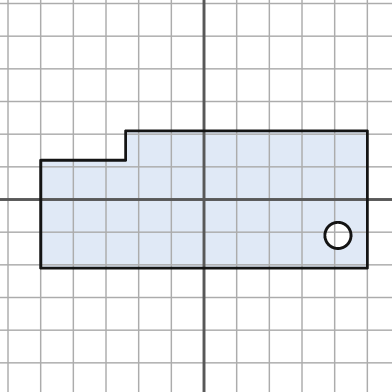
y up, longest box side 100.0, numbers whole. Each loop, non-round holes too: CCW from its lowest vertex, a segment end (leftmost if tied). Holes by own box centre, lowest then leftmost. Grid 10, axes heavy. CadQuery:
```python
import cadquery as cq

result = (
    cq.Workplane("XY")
    .moveTo(-50.0, -21.0)
    .lineTo(50.0, -21.0)
    .lineTo(50.0, 21.0)
    .lineTo(-24.0, 21.0)
    .lineTo(-24.0, 12.0)
    .lineTo(-50.0, 12.0)
    .close()
    .moveTo(41.0, -11.0)
    .circle(4.0)
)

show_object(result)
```